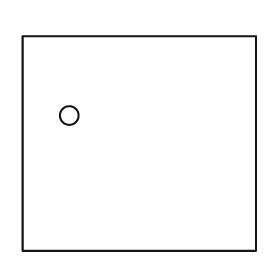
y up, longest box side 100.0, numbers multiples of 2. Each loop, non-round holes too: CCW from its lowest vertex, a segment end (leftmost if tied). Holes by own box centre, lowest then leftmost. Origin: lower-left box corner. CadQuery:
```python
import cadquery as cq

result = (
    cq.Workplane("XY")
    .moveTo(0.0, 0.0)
    .lineTo(100.0, 0.0)
    .lineTo(100.0, 92.0)
    .lineTo(0.0, 92.0)
    .close()
    .moveTo(20.0, 58.0)
    .circle(4.0)
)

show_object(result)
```